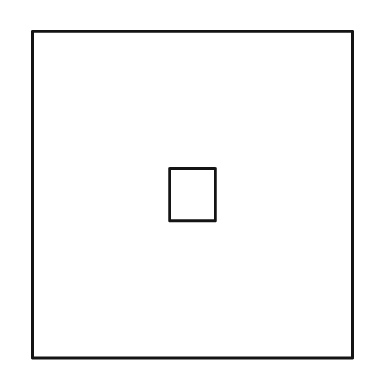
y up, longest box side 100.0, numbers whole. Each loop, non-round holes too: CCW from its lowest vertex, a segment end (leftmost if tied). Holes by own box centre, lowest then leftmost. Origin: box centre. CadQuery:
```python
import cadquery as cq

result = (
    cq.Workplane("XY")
    .moveTo(-49.0, -50.0)
    .lineTo(49.0, -50.0)
    .lineTo(49.0, 50.0)
    .lineTo(-49.0, 50.0)
    .close()
    .moveTo(-7.0, -8.0)
    .lineTo(7.0, -8.0)
    .lineTo(7.0, 8.0)
    .lineTo(-7.0, 8.0)
    .close()
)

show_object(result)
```